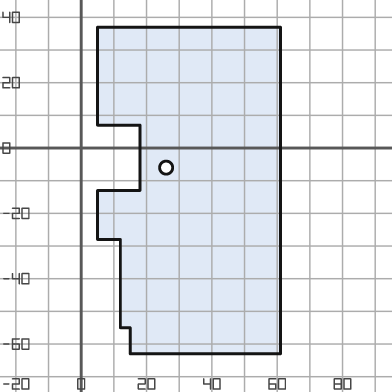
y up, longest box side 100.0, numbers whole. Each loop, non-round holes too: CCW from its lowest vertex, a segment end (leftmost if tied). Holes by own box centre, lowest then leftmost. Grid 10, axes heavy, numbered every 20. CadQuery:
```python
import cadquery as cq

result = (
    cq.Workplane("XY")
    .moveTo(15.0, -63.0)
    .lineTo(61.0, -63.0)
    .lineTo(61.0, 37.0)
    .lineTo(5.0, 37.0)
    .lineTo(5.0, 7.0)
    .lineTo(18.0, 7.0)
    .lineTo(18.0, -13.0)
    .lineTo(5.0, -13.0)
    .lineTo(5.0, -28.0)
    .lineTo(12.0, -28.0)
    .lineTo(12.0, -55.0)
    .lineTo(15.0, -55.0)
    .close()
    .moveTo(26.0, -6.0)
    .circle(2.0)
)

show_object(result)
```